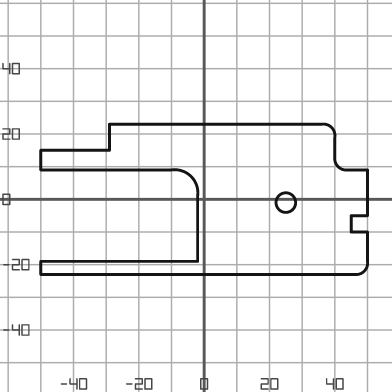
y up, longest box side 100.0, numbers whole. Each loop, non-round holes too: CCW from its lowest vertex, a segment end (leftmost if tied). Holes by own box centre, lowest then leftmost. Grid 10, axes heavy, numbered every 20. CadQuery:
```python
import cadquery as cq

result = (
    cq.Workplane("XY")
    .moveTo(-50.0, -23.0)
    .lineTo(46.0, -23.0)
    .threePointArc((49.0, -22.0), (50.0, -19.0))
    .lineTo(50.0, -10.0)
    .lineTo(45.0, -10.0)
    .lineTo(45.0, -5.0)
    .lineTo(50.0, -5.0)
    .lineTo(50.0, 9.0)
    .lineTo(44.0, 9.0)
    .threePointArc((41.0, 10.0), (40.0, 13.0))
    .lineTo(40.0, 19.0)
    .threePointArc((39.0, 22.0), (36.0, 23.0))
    .lineTo(-29.0, 23.0)
    .lineTo(-29.0, 15.0)
    .lineTo(-50.0, 15.0)
    .lineTo(-50.0, 9.0)
    .lineTo(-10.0, 9.0)
    .threePointArc((-4.0, 7.0), (-2.0, 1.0))
    .lineTo(-2.0, -19.0)
    .lineTo(-50.0, -19.0)
    .close()
    .moveTo(25.0, -1.0)
    .circle(3.0)
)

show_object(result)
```